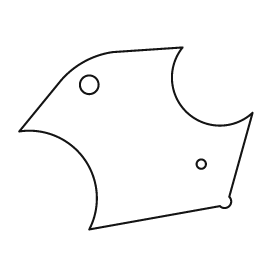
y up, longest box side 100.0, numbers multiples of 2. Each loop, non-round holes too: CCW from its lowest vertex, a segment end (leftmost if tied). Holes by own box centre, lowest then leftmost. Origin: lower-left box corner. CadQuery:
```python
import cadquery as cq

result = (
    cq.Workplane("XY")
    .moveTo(30.0, 0.0)
    .lineTo(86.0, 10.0)
    .threePointArc((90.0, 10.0), (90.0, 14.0))
    .lineTo(100.0, 50.0)
    .threePointArc((72.0, 50.0), (70.0, 78.0))
    .lineTo(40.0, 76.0)
    .threePointArc((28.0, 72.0), (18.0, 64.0))
    .lineTo(0.0, 42.0)
    .threePointArc((28.0, 30.0), (30.0, 0.0))
    .close()
    .moveTo(78.0, 28.0)
    .circle(2.0)
    .moveTo(30.0, 62.0)
    .circle(4.0)
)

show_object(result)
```